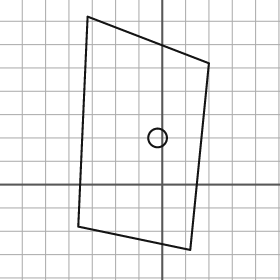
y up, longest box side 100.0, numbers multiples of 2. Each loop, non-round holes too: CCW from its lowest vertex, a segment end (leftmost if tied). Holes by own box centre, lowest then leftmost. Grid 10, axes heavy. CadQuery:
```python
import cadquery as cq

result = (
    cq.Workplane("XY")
    .moveTo(12.0, -28.0)
    .lineTo(20.0, 52.0)
    .lineTo(-32.0, 72.0)
    .lineTo(-36.0, -18.0)
    .close()
    .moveTo(-2.0, 20.0)
    .circle(4.0)
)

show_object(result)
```